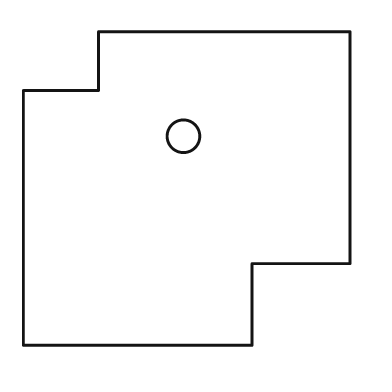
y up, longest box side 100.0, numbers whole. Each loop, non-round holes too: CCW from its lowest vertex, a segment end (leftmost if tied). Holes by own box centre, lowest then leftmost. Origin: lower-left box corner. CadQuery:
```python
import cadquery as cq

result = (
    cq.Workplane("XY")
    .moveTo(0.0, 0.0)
    .lineTo(70.0, 0.0)
    .lineTo(70.0, 25.0)
    .lineTo(100.0, 25.0)
    .lineTo(100.0, 96.0)
    .lineTo(23.0, 96.0)
    .lineTo(23.0, 78.0)
    .lineTo(0.0, 78.0)
    .close()
    .moveTo(49.0, 64.0)
    .circle(5.0)
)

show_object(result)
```